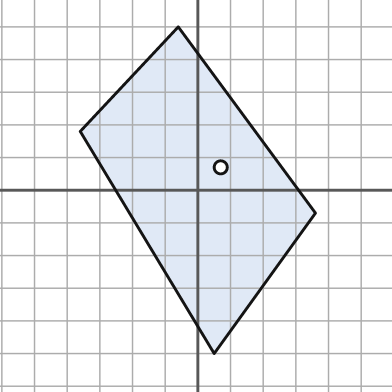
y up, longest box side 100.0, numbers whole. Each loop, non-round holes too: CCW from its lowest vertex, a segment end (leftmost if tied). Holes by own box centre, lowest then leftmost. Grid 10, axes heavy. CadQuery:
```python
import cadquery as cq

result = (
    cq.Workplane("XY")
    .moveTo(5.0, -50.0)
    .lineTo(36.0, -7.0)
    .lineTo(-6.0, 50.0)
    .lineTo(-36.0, 18.0)
    .close()
    .moveTo(7.0, 7.0)
    .circle(2.0)
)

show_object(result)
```